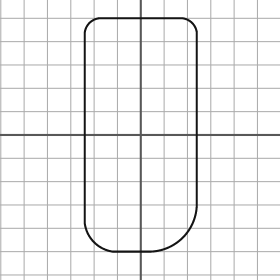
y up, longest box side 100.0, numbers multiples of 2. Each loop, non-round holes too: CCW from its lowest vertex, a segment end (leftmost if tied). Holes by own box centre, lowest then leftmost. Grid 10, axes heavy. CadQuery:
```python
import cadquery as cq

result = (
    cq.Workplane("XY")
    .moveTo(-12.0, -50.0)
    .lineTo(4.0, -50.0)
    .threePointArc((18.0, -44.0), (24.0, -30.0))
    .lineTo(24.0, 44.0)
    .threePointArc((22.0, 48.0), (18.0, 50.0))
    .lineTo(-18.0, 50.0)
    .threePointArc((-22.0, 48.0), (-24.0, 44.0))
    .lineTo(-24.0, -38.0)
    .threePointArc((-20.0, -46.0), (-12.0, -50.0))
    .close()
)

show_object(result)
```